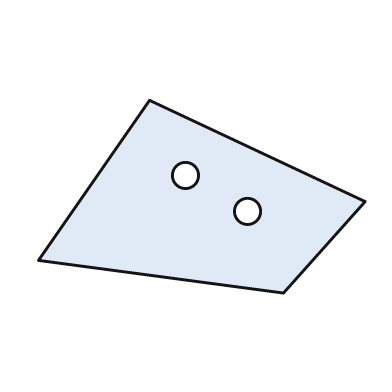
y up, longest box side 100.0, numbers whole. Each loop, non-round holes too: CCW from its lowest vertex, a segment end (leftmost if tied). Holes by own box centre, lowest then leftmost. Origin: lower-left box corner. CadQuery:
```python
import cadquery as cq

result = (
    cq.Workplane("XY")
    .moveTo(75.0, 0.0)
    .lineTo(100.0, 28.0)
    .lineTo(34.0, 59.0)
    .lineTo(0.0, 10.0)
    .close()
    .moveTo(64.0, 25.0)
    .circle(4.0)
    .moveTo(45.0, 36.0)
    .circle(4.0)
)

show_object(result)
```